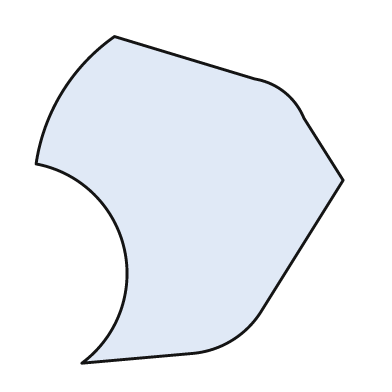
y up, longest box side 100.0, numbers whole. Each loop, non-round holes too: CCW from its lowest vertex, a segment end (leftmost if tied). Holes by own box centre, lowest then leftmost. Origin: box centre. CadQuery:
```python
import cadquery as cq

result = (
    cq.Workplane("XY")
    .moveTo(-33.0, -50.0)
    .lineTo(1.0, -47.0)
    .threePointArc((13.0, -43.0), (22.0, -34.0))
    .lineTo(47.0, 6.0)
    .lineTo(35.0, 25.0)
    .threePointArc((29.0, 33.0), (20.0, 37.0))
    .lineTo(-23.0, 50.0)
    .threePointArc((-39.0, 33.0), (-47.0, 11.0))
    .threePointArc((-20.0, -15.0), (-33.0, -50.0))
    .close()
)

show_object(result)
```